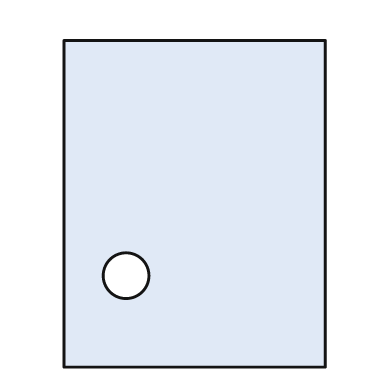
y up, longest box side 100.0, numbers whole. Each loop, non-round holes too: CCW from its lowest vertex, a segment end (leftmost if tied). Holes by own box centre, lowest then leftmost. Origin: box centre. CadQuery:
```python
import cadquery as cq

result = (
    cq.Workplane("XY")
    .moveTo(-40.0, -50.0)
    .lineTo(40.0, -50.0)
    .lineTo(40.0, 50.0)
    .lineTo(-40.0, 50.0)
    .close()
    .moveTo(-21.0, -22.0)
    .circle(7.0)
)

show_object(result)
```